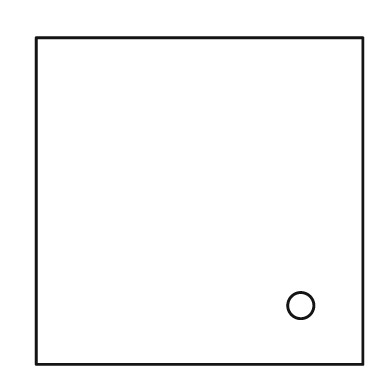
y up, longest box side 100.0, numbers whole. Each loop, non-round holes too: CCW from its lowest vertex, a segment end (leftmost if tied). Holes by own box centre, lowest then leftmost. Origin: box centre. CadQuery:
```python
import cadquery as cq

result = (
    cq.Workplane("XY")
    .moveTo(-50.0, -50.0)
    .lineTo(50.0, -50.0)
    .lineTo(50.0, 50.0)
    .lineTo(-50.0, 50.0)
    .close()
    .moveTo(31.0, -32.0)
    .circle(4.0)
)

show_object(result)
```